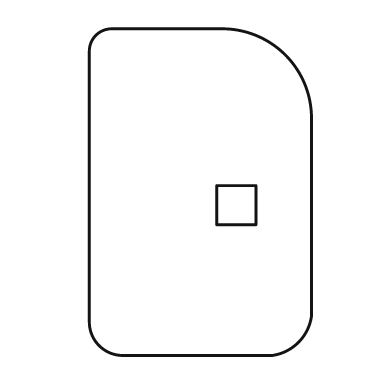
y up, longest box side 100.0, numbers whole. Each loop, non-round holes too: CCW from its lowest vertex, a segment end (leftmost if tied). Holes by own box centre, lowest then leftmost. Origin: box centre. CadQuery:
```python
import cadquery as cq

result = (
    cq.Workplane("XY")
    .moveTo(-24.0, -50.0)
    .lineTo(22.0, -50.0)
    .threePointArc((30.0, -46.0), (34.0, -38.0))
    .lineTo(34.0, 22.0)
    .threePointArc((26.0, 42.0), (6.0, 50.0))
    .lineTo(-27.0, 50.0)
    .threePointArc((-32.0, 48.0), (-34.0, 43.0))
    .lineTo(-34.0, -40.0)
    .threePointArc((-31.0, -47.0), (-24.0, -50.0))
    .close()
    .moveTo(5.0, -10.0)
    .lineTo(17.0, -10.0)
    .lineTo(17.0, 2.0)
    .lineTo(5.0, 2.0)
    .close()
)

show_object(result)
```